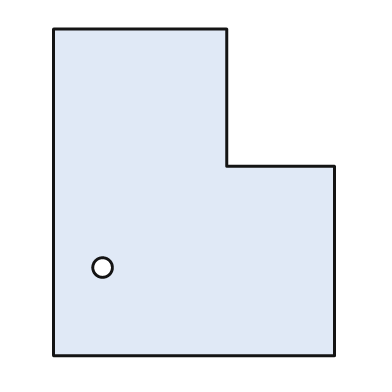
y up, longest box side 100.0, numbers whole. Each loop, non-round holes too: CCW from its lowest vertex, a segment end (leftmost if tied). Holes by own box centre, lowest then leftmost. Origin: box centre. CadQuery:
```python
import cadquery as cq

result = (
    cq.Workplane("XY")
    .moveTo(-43.0, -50.0)
    .lineTo(43.0, -50.0)
    .lineTo(43.0, 8.0)
    .lineTo(10.0, 8.0)
    .lineTo(10.0, 50.0)
    .lineTo(-43.0, 50.0)
    .close()
    .moveTo(-28.0, -23.0)
    .circle(3.0)
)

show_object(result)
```